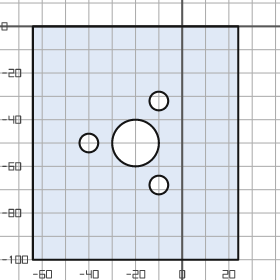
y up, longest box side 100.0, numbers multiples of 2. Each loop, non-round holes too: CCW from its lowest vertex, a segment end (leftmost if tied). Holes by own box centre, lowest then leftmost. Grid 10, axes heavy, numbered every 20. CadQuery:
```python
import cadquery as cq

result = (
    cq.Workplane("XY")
    .moveTo(-64.0, -100.0)
    .lineTo(24.0, -100.0)
    .lineTo(24.0, 0.0)
    .lineTo(-64.0, 0.0)
    .close()
    .moveTo(-10.0, -68.0)
    .circle(4.0)
    .moveTo(-40.0, -50.0)
    .circle(4.0)
    .moveTo(-20.0, -50.0)
    .circle(10.0)
    .moveTo(-10.0, -32.0)
    .circle(4.0)
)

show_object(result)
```